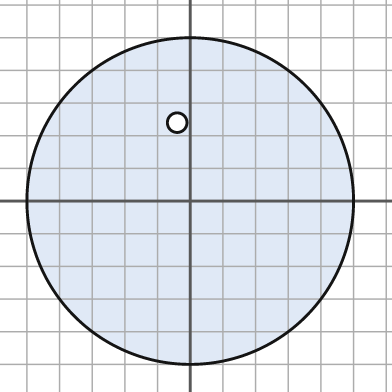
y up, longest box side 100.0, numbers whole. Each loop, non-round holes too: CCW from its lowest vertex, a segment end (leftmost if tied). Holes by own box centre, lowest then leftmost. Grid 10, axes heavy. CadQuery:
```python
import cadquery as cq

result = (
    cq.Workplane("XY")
    .moveTo(0.0, 0.0)
    .circle(50.0)
    .moveTo(-4.0, 24.0)
    .circle(3.0)
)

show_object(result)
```